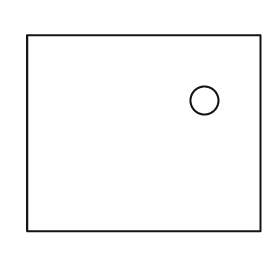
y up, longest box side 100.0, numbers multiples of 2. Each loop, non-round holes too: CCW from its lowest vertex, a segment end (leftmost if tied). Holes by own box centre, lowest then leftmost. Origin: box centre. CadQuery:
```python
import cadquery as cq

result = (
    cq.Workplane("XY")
    .moveTo(-50.0, -42.0)
    .lineTo(50.0, -42.0)
    .lineTo(50.0, 42.0)
    .lineTo(-50.0, 42.0)
    .close()
    .moveTo(26.0, 14.0)
    .circle(6.0)
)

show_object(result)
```